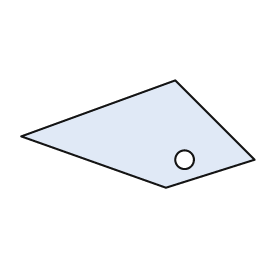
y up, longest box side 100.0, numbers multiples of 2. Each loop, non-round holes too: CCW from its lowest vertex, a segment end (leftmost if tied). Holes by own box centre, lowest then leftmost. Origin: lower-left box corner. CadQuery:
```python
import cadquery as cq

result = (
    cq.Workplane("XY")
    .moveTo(62.0, 0.0)
    .lineTo(100.0, 12.0)
    .lineTo(66.0, 46.0)
    .lineTo(0.0, 22.0)
    .close()
    .moveTo(70.0, 12.0)
    .circle(4.0)
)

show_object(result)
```